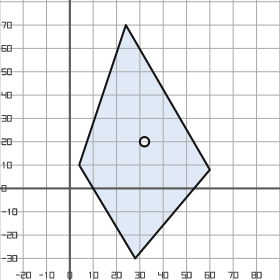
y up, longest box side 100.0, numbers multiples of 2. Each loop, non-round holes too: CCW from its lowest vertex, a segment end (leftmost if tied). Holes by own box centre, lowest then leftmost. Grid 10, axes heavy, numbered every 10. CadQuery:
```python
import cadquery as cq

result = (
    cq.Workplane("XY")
    .moveTo(28.0, -30.0)
    .lineTo(60.0, 8.0)
    .lineTo(24.0, 70.0)
    .lineTo(4.0, 10.0)
    .close()
    .moveTo(32.0, 20.0)
    .circle(2.0)
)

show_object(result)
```